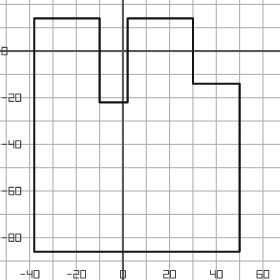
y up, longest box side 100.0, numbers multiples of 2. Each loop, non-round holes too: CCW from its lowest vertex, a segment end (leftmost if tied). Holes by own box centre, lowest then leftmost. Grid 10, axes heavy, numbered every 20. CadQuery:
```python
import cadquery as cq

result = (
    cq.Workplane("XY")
    .moveTo(-38.0, -86.0)
    .lineTo(50.0, -86.0)
    .lineTo(50.0, -14.0)
    .lineTo(30.0, -14.0)
    .lineTo(30.0, 14.0)
    .lineTo(2.0, 14.0)
    .lineTo(2.0, -22.0)
    .lineTo(-10.0, -22.0)
    .lineTo(-10.0, 14.0)
    .lineTo(-38.0, 14.0)
    .close()
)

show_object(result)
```